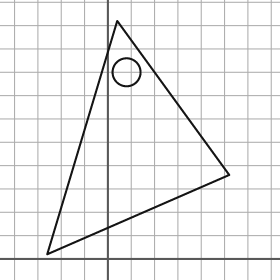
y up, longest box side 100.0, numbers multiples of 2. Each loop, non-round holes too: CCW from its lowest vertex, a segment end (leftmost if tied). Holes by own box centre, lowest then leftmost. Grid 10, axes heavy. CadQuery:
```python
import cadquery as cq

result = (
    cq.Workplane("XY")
    .moveTo(-26.0, 2.0)
    .lineTo(52.0, 36.0)
    .lineTo(4.0, 102.0)
    .close()
    .moveTo(8.0, 80.0)
    .circle(6.0)
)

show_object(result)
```